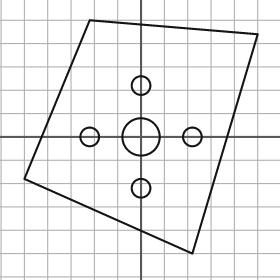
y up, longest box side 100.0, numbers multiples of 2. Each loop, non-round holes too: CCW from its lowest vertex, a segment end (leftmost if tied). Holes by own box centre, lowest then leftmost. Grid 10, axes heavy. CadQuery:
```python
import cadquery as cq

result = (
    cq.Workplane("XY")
    .moveTo(22.0, -50.0)
    .lineTo(50.0, 44.0)
    .lineTo(-22.0, 50.0)
    .lineTo(-50.0, -18.0)
    .close()
    .moveTo(0.0, -22.0)
    .circle(4.0)
    .moveTo(-22.0, 0.0)
    .circle(4.0)
    .moveTo(0.0, 0.0)
    .circle(8.0)
    .moveTo(22.0, 0.0)
    .circle(4.0)
    .moveTo(0.0, 22.0)
    .circle(4.0)
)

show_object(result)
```